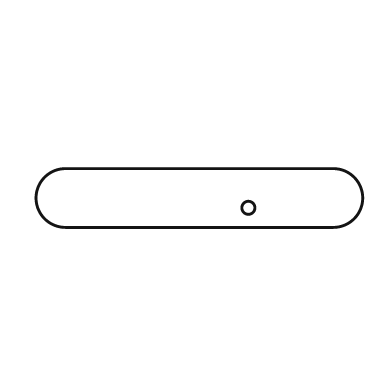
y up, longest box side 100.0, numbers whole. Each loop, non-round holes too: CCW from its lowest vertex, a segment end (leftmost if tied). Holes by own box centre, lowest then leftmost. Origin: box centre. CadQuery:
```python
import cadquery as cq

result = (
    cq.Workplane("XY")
    .moveTo(-41.0, -9.0)
    .lineTo(41.0, -9.0)
    .threePointArc((50.0, 0.0), (41.0, 9.0))
    .lineTo(-41.0, 9.0)
    .threePointArc((-50.0, 0.0), (-41.0, -9.0))
    .close()
    .moveTo(15.0, -3.0)
    .circle(2.0)
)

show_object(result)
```